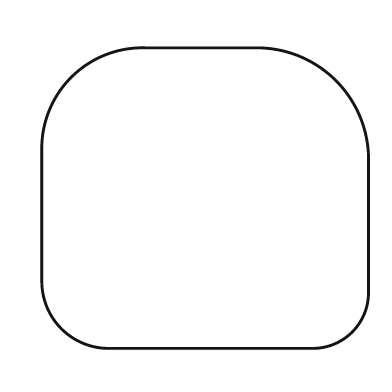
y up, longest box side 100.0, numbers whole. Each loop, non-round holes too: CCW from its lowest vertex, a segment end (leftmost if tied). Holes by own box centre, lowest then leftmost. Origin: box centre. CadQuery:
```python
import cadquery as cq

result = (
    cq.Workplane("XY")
    .moveTo(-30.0, -46.0)
    .lineTo(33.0, -46.0)
    .threePointArc((45.0, -41.0), (50.0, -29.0))
    .lineTo(50.0, 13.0)
    .threePointArc((40.0, 36.0), (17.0, 46.0))
    .lineTo(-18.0, 46.0)
    .threePointArc((-41.0, 37.0), (-50.0, 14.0))
    .lineTo(-50.0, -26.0)
    .threePointArc((-44.0, -40.0), (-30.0, -46.0))
    .close()
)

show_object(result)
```